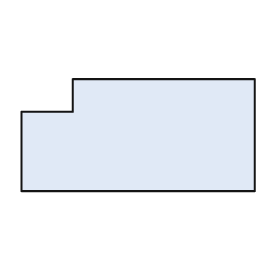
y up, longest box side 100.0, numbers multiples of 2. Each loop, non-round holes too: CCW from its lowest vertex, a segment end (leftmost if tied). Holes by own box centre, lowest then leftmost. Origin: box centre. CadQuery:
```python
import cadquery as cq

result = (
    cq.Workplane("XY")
    .moveTo(-50.0, -24.0)
    .lineTo(50.0, -24.0)
    .lineTo(50.0, 24.0)
    .lineTo(-28.0, 24.0)
    .lineTo(-28.0, 10.0)
    .lineTo(-50.0, 10.0)
    .close()
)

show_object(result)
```